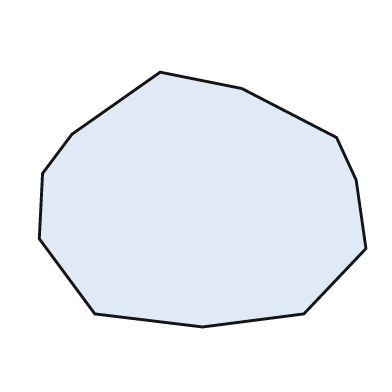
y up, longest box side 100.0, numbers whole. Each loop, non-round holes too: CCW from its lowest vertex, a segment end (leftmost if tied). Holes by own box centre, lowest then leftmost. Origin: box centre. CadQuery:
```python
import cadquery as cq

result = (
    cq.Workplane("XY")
    .moveTo(0.0, -39.0)
    .lineTo(31.0, -35.0)
    .lineTo(50.0, -15.0)
    .lineTo(47.0, 6.0)
    .lineTo(41.0, 19.0)
    .lineTo(12.0, 34.0)
    .lineTo(-13.0, 39.0)
    .lineTo(-40.0, 20.0)
    .lineTo(-49.0, 8.0)
    .lineTo(-50.0, -12.0)
    .lineTo(-33.0, -35.0)
    .close()
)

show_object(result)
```